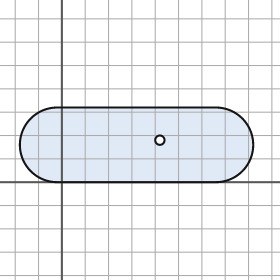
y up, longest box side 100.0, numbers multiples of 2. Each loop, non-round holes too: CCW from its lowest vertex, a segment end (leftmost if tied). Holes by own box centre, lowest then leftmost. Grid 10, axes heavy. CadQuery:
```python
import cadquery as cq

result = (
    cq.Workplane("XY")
    .moveTo(-2.0, 0.0)
    .lineTo(66.0, 0.0)
    .threePointArc((82.0, 16.0), (66.0, 32.0))
    .lineTo(-2.0, 32.0)
    .threePointArc((-18.0, 16.0), (-2.0, 0.0))
    .close()
    .moveTo(42.0, 18.0)
    .circle(2.0)
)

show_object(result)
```